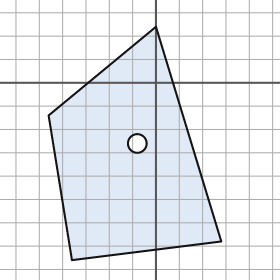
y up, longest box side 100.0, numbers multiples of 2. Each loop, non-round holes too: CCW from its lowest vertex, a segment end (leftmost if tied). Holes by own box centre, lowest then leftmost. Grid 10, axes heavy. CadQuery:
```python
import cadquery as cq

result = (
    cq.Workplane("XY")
    .moveTo(-36.0, -76.0)
    .lineTo(28.0, -68.0)
    .lineTo(0.0, 24.0)
    .lineTo(-46.0, -14.0)
    .close()
    .moveTo(-8.0, -26.0)
    .circle(4.0)
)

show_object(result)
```